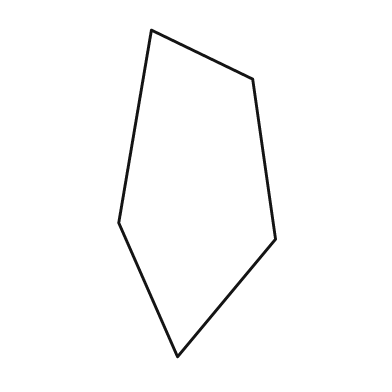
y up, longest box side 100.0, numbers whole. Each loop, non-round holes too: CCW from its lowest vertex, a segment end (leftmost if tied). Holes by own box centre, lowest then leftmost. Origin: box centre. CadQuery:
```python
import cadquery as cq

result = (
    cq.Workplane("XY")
    .moveTo(-6.0, -50.0)
    .lineTo(24.0, -14.0)
    .lineTo(17.0, 35.0)
    .lineTo(-14.0, 50.0)
    .lineTo(-24.0, -9.0)
    .close()
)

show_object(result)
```